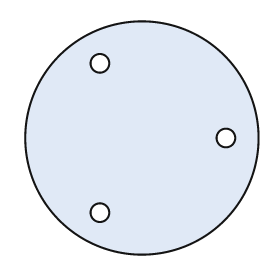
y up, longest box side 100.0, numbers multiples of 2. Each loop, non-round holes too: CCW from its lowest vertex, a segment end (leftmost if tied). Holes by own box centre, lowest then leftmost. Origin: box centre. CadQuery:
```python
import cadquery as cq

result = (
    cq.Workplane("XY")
    .moveTo(0.0, 0.0)
    .circle(50.0)
    .moveTo(-18.0, -32.0)
    .circle(4.0)
    .moveTo(36.0, 0.0)
    .circle(4.0)
    .moveTo(-18.0, 32.0)
    .circle(4.0)
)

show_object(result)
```